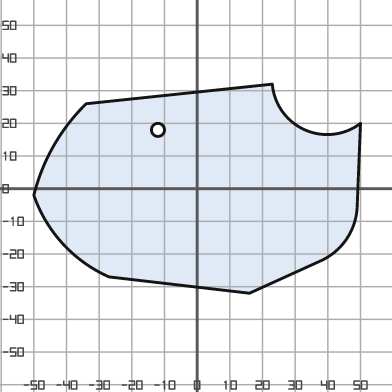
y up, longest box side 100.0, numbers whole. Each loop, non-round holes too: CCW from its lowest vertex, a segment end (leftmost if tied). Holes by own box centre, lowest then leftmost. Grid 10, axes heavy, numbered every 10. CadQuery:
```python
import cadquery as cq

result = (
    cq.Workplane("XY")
    .moveTo(16.0, -32.0)
    .lineTo(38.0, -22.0)
    .threePointArc((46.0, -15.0), (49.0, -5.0))
    .lineTo(50.0, 20.0)
    .threePointArc((33.0, 18.0), (23.0, 32.0))
    .lineTo(-34.0, 26.0)
    .threePointArc((-44.0, 13.0), (-50.0, -2.0))
    .threePointArc((-41.0, -17.0), (-27.0, -27.0))
    .close()
    .moveTo(-12.0, 18.0)
    .circle(2.0)
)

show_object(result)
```